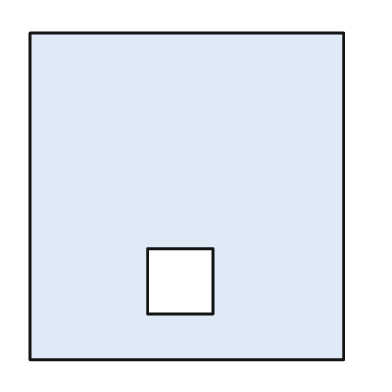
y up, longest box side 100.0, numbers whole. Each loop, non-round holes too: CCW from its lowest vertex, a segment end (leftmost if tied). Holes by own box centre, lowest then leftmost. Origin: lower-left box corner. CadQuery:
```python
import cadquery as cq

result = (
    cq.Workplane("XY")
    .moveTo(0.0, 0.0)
    .lineTo(96.0, 0.0)
    .lineTo(96.0, 100.0)
    .lineTo(0.0, 100.0)
    .close()
    .moveTo(36.0, 14.0)
    .lineTo(56.0, 14.0)
    .lineTo(56.0, 34.0)
    .lineTo(36.0, 34.0)
    .close()
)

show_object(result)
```